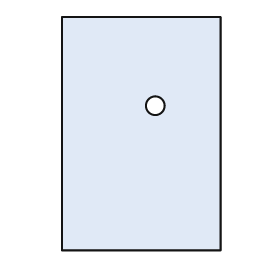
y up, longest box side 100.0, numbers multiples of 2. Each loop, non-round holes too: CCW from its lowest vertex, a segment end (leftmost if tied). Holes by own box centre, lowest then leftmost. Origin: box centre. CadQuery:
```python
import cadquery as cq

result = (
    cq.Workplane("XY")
    .moveTo(-34.0, -50.0)
    .lineTo(34.0, -50.0)
    .lineTo(34.0, 50.0)
    .lineTo(-34.0, 50.0)
    .close()
    .moveTo(6.0, 12.0)
    .circle(4.0)
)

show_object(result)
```